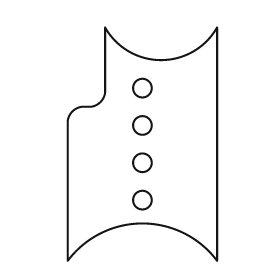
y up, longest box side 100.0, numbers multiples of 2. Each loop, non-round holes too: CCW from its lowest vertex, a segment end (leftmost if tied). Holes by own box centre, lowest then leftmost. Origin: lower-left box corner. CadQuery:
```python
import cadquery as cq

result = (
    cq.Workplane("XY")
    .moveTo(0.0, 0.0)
    .threePointArc((32.0, 16.0), (64.0, 0.0))
    .lineTo(64.0, 100.0)
    .threePointArc((40.0, 86.0), (16.0, 100.0))
    .lineTo(16.0, 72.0)
    .threePointArc((14.0, 68.0), (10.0, 66.0))
    .lineTo(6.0, 66.0)
    .threePointArc((2.0, 64.0), (0.0, 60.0))
    .close()
    .moveTo(32.0, 26.0)
    .circle(4.0)
    .moveTo(32.0, 42.0)
    .circle(4.0)
    .moveTo(32.0, 58.0)
    .circle(4.0)
    .moveTo(32.0, 74.0)
    .circle(4.0)
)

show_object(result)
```